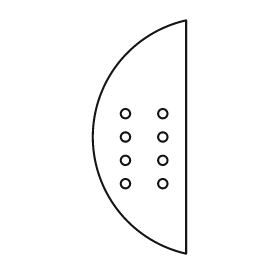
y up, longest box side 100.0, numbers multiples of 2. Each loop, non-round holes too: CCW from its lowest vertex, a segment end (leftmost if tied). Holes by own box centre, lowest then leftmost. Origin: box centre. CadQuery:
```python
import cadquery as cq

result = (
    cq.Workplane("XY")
    .moveTo(20.0, -50.0)
    .lineTo(20.0, 50.0)
    .threePointArc((-20.0, 0.0), (20.0, -50.0))
    .close()
    .moveTo(-6.0, -20.0)
    .circle(2.0)
    .moveTo(10.0, -20.0)
    .circle(2.0)
    .moveTo(-6.0, -10.0)
    .circle(2.0)
    .moveTo(10.0, -10.0)
    .circle(2.0)
    .moveTo(-6.0, 0.0)
    .circle(2.0)
    .moveTo(10.0, 0.0)
    .circle(2.0)
    .moveTo(-6.0, 10.0)
    .circle(2.0)
    .moveTo(10.0, 10.0)
    .circle(2.0)
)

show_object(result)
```